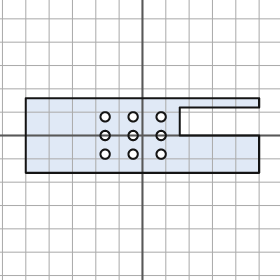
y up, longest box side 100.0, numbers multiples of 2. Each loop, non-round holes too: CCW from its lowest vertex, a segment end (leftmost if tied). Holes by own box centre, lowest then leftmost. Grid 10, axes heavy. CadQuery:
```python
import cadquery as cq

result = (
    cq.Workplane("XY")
    .moveTo(-50.0, -16.0)
    .lineTo(50.0, -16.0)
    .lineTo(50.0, 0.0)
    .lineTo(16.0, 0.0)
    .lineTo(16.0, 12.0)
    .lineTo(50.0, 12.0)
    .lineTo(50.0, 16.0)
    .lineTo(-50.0, 16.0)
    .close()
    .moveTo(-16.0, -8.0)
    .circle(2.0)
    .moveTo(-4.0, -8.0)
    .circle(2.0)
    .moveTo(8.0, -8.0)
    .circle(2.0)
    .moveTo(-16.0, 0.0)
    .circle(2.0)
    .moveTo(-4.0, 0.0)
    .circle(2.0)
    .moveTo(8.0, 0.0)
    .circle(2.0)
    .moveTo(-16.0, 8.0)
    .circle(2.0)
    .moveTo(-4.0, 8.0)
    .circle(2.0)
    .moveTo(8.0, 8.0)
    .circle(2.0)
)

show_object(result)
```